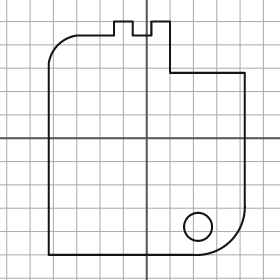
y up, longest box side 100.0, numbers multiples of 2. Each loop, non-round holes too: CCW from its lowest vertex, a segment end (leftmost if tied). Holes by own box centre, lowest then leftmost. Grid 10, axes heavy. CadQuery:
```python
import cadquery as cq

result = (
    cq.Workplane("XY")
    .moveTo(-42.0, -50.0)
    .lineTo(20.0, -50.0)
    .threePointArc((36.0, -44.0), (42.0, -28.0))
    .lineTo(42.0, 28.0)
    .lineTo(10.0, 28.0)
    .lineTo(10.0, 50.0)
    .lineTo(2.0, 50.0)
    .lineTo(2.0, 44.0)
    .lineTo(-6.0, 44.0)
    .lineTo(-6.0, 50.0)
    .lineTo(-14.0, 50.0)
    .lineTo(-14.0, 44.0)
    .lineTo(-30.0, 44.0)
    .threePointArc((-38.0, 40.0), (-42.0, 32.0))
    .close()
    .moveTo(22.0, -38.0)
    .circle(6.0)
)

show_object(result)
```